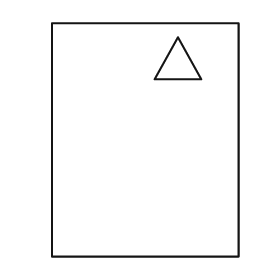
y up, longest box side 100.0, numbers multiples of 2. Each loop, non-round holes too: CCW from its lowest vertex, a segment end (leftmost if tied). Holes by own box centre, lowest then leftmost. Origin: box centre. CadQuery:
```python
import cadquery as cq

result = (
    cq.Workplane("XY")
    .moveTo(-40.0, -50.0)
    .lineTo(40.0, -50.0)
    .lineTo(40.0, 50.0)
    .lineTo(-40.0, 50.0)
    .close()
    .moveTo(4.0, 26.0)
    .lineTo(24.0, 26.0)
    .lineTo(14.0, 44.0)
    .close()
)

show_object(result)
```